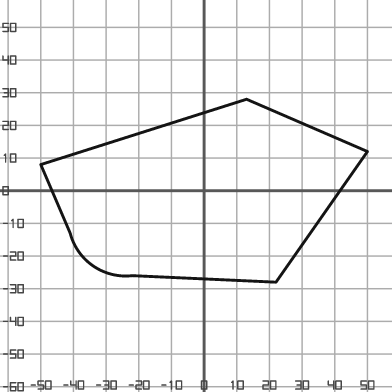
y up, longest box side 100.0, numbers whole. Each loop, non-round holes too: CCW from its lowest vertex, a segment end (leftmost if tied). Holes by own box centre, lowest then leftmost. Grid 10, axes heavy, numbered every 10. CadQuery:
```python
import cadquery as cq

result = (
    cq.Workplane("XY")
    .moveTo(22.0, -28.0)
    .lineTo(50.0, 12.0)
    .lineTo(13.0, 28.0)
    .lineTo(-50.0, 8.0)
    .lineTo(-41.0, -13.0)
    .threePointArc((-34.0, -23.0), (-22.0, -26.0))
    .close()
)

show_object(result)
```